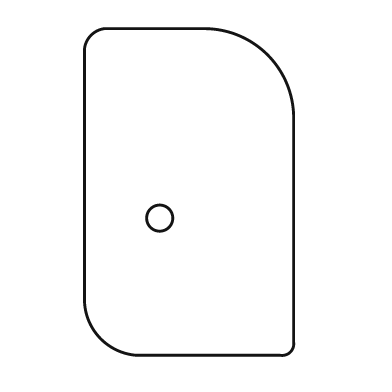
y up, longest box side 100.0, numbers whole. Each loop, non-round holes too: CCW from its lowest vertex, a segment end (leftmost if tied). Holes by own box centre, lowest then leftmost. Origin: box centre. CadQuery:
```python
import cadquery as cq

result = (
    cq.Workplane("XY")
    .moveTo(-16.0, -50.0)
    .lineTo(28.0, -50.0)
    .threePointArc((31.0, -49.0), (32.0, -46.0))
    .lineTo(32.0, 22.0)
    .threePointArc((24.0, 42.0), (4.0, 50.0))
    .lineTo(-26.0, 50.0)
    .threePointArc((-30.0, 48.0), (-32.0, 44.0))
    .lineTo(-32.0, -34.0)
    .threePointArc((-27.0, -45.0), (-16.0, -50.0))
    .close()
    .moveTo(-9.0, -8.0)
    .circle(4.0)
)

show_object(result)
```